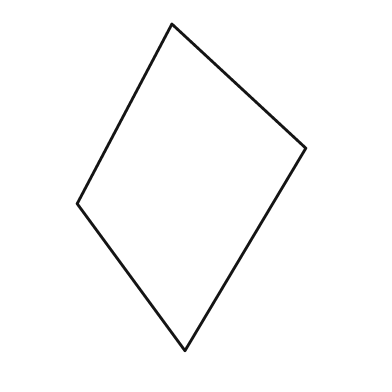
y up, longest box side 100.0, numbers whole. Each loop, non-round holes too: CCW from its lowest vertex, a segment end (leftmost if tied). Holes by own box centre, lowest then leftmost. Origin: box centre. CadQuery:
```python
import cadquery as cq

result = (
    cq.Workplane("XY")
    .moveTo(-2.0, -50.0)
    .lineTo(35.0, 12.0)
    .lineTo(-6.0, 50.0)
    .lineTo(-35.0, -5.0)
    .close()
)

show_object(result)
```